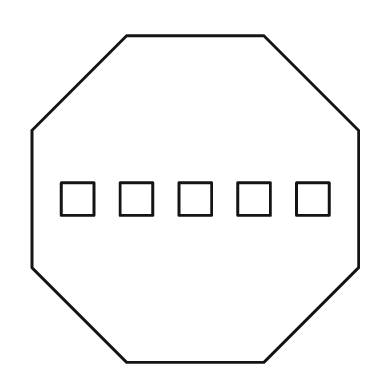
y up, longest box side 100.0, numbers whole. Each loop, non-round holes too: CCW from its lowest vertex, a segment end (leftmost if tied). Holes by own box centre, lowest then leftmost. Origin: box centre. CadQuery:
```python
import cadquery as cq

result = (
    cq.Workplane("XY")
    .moveTo(-21.0, -50.0)
    .lineTo(21.0, -50.0)
    .lineTo(50.0, -21.0)
    .lineTo(50.0, 21.0)
    .lineTo(21.0, 50.0)
    .lineTo(-21.0, 50.0)
    .lineTo(-50.0, 21.0)
    .lineTo(-50.0, -21.0)
    .close()
    .moveTo(-41.0, -5.0)
    .lineTo(-31.0, -5.0)
    .lineTo(-31.0, 5.0)
    .lineTo(-41.0, 5.0)
    .close()
    .moveTo(-23.0, -5.0)
    .lineTo(-13.0, -5.0)
    .lineTo(-13.0, 5.0)
    .lineTo(-23.0, 5.0)
    .close()
    .moveTo(-5.0, -5.0)
    .lineTo(5.0, -5.0)
    .lineTo(5.0, 5.0)
    .lineTo(-5.0, 5.0)
    .close()
    .moveTo(13.0, -5.0)
    .lineTo(23.0, -5.0)
    .lineTo(23.0, 5.0)
    .lineTo(13.0, 5.0)
    .close()
    .moveTo(31.0, -5.0)
    .lineTo(41.0, -5.0)
    .lineTo(41.0, 5.0)
    .lineTo(31.0, 5.0)
    .close()
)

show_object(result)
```